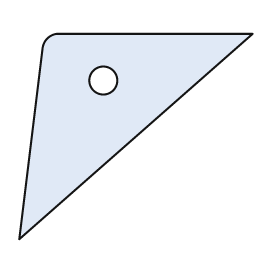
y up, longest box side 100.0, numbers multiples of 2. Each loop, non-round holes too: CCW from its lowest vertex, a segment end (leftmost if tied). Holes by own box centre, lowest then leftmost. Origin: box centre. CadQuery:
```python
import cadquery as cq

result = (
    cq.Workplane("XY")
    .moveTo(-50.0, -44.0)
    .lineTo(50.0, 44.0)
    .lineTo(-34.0, 44.0)
    .threePointArc((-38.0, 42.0), (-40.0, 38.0))
    .close()
    .moveTo(-14.0, 24.0)
    .circle(6.0)
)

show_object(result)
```